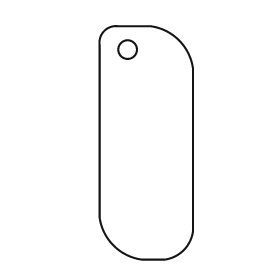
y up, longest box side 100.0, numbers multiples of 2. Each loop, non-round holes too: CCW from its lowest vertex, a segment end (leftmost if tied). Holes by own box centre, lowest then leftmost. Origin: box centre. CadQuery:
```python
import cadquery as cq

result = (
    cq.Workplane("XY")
    .moveTo(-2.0, -50.0)
    .lineTo(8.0, -50.0)
    .threePointArc((16.0, -46.0), (20.0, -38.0))
    .lineTo(20.0, 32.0)
    .threePointArc((14.0, 44.0), (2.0, 50.0))
    .lineTo(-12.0, 50.0)
    .threePointArc((-18.0, 48.0), (-20.0, 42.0))
    .lineTo(-20.0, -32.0)
    .threePointArc((-14.0, -44.0), (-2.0, -50.0))
    .close()
    .moveTo(-8.0, 40.0)
    .circle(4.0)
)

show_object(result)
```